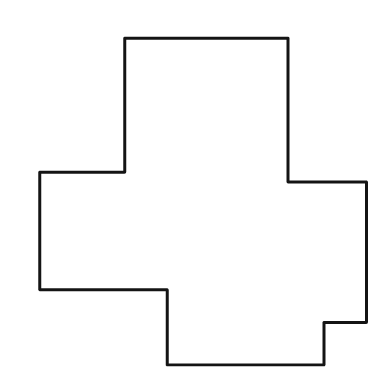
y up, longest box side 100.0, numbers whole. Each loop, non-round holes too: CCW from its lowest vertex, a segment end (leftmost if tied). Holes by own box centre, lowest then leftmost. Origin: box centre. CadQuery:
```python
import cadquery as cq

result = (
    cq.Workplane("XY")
    .moveTo(-11.0, -50.0)
    .lineTo(37.0, -50.0)
    .lineTo(37.0, -37.0)
    .lineTo(50.0, -37.0)
    .lineTo(50.0, 6.0)
    .lineTo(26.0, 6.0)
    .lineTo(26.0, 50.0)
    .lineTo(-24.0, 50.0)
    .lineTo(-24.0, 9.0)
    .lineTo(-50.0, 9.0)
    .lineTo(-50.0, -27.0)
    .lineTo(-11.0, -27.0)
    .close()
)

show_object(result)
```